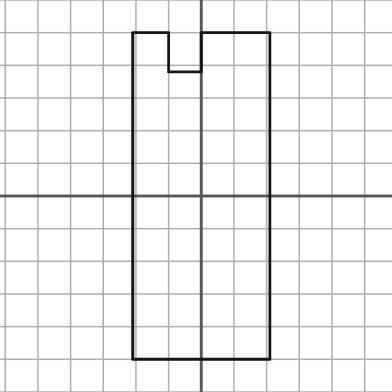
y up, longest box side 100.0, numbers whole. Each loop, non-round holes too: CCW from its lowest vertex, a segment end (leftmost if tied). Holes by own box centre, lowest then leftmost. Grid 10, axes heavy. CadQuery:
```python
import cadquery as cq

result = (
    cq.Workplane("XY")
    .moveTo(-21.0, -50.0)
    .lineTo(21.0, -50.0)
    .lineTo(21.0, 50.0)
    .lineTo(0.0, 50.0)
    .lineTo(0.0, 38.0)
    .lineTo(-10.0, 38.0)
    .lineTo(-10.0, 50.0)
    .lineTo(-21.0, 50.0)
    .close()
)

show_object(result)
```